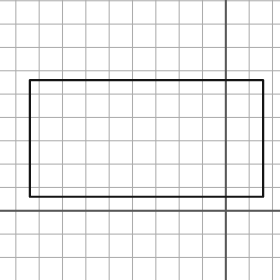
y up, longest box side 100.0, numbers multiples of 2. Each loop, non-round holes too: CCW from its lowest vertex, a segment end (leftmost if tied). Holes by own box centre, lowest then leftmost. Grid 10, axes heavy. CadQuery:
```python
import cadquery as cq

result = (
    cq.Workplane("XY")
    .moveTo(-84.0, 6.0)
    .lineTo(16.0, 6.0)
    .lineTo(16.0, 56.0)
    .lineTo(-84.0, 56.0)
    .close()
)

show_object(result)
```